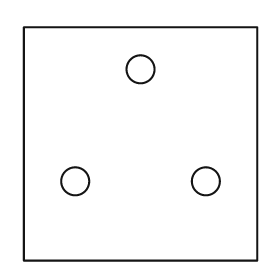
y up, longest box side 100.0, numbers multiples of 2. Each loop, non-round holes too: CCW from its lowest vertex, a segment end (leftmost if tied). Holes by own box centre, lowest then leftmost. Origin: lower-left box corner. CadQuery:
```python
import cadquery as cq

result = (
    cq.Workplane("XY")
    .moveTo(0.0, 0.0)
    .lineTo(100.0, 0.0)
    .lineTo(100.0, 100.0)
    .lineTo(0.0, 100.0)
    .close()
    .moveTo(22.0, 34.0)
    .circle(6.0)
    .moveTo(78.0, 34.0)
    .circle(6.0)
    .moveTo(50.0, 82.0)
    .circle(6.0)
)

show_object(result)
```